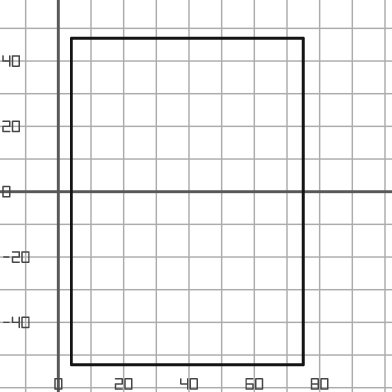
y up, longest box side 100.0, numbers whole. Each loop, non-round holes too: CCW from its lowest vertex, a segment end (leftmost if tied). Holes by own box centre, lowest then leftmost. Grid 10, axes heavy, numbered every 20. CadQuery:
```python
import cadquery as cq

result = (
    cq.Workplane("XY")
    .moveTo(4.0, -53.0)
    .lineTo(75.0, -53.0)
    .lineTo(75.0, 47.0)
    .lineTo(4.0, 47.0)
    .close()
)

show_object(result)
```